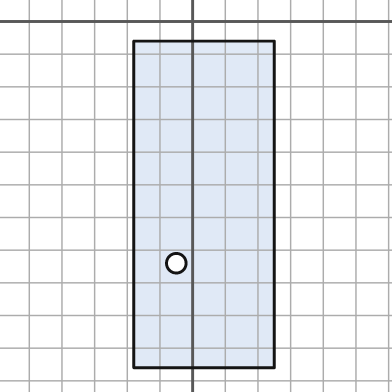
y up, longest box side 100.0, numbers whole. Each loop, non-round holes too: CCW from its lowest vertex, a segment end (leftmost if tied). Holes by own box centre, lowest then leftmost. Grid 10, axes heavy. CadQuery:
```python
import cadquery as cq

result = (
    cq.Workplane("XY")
    .moveTo(-18.0, -106.0)
    .lineTo(25.0, -106.0)
    .lineTo(25.0, -6.0)
    .lineTo(-18.0, -6.0)
    .close()
    .moveTo(-5.0, -74.0)
    .circle(3.0)
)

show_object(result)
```